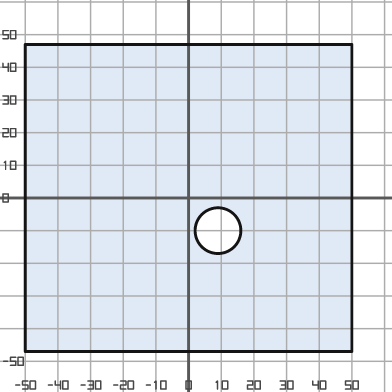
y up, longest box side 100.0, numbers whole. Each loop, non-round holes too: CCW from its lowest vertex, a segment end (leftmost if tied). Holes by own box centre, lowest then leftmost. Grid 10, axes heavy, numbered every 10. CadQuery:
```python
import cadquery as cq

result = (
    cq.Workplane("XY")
    .moveTo(-50.0, -47.0)
    .lineTo(50.0, -47.0)
    .lineTo(50.0, 47.0)
    .lineTo(-50.0, 47.0)
    .close()
    .moveTo(9.0, -10.0)
    .circle(7.0)
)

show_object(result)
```